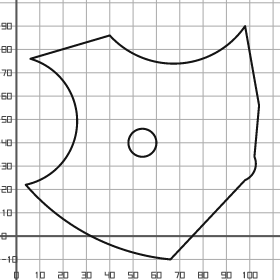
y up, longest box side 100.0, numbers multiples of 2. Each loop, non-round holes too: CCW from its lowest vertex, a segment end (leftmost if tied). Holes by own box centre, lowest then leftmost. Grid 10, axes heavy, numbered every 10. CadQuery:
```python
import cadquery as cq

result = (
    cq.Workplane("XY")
    .moveTo(66.0, -10.0)
    .lineTo(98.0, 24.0)
    .threePointArc((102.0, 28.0), (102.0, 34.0))
    .lineTo(104.0, 56.0)
    .lineTo(98.0, 90.0)
    .threePointArc((70.0, 74.0), (40.0, 86.0))
    .lineTo(6.0, 76.0)
    .threePointArc((26.0, 48.0), (4.0, 22.0))
    .threePointArc((32.0, 0.0), (66.0, -10.0))
    .close()
    .moveTo(54.0, 40.0)
    .circle(6.0)
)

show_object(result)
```